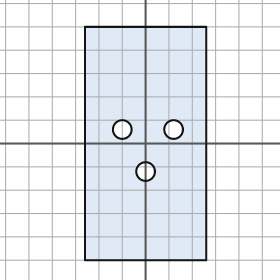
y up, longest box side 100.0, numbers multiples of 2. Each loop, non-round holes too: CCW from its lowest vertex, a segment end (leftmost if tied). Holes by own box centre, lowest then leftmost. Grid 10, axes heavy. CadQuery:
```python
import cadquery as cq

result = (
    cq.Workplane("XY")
    .moveTo(-26.0, -50.0)
    .lineTo(26.0, -50.0)
    .lineTo(26.0, 50.0)
    .lineTo(-26.0, 50.0)
    .close()
    .moveTo(0.0, -12.0)
    .circle(4.0)
    .moveTo(-10.0, 6.0)
    .circle(4.0)
    .moveTo(12.0, 6.0)
    .circle(4.0)
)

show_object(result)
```